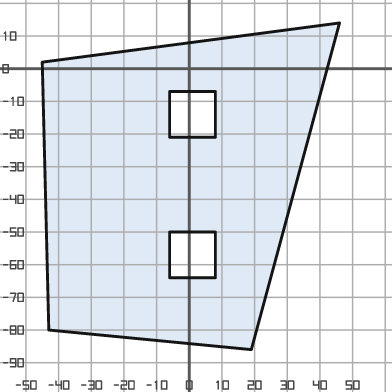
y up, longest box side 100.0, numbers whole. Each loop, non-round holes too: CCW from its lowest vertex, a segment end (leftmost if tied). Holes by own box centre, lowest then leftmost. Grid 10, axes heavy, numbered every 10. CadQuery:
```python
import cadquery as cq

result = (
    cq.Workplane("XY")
    .moveTo(19.0, -86.0)
    .lineTo(46.0, 14.0)
    .lineTo(-45.0, 2.0)
    .lineTo(-43.0, -80.0)
    .close()
    .moveTo(-6.0, -64.0)
    .lineTo(8.0, -64.0)
    .lineTo(8.0, -50.0)
    .lineTo(-6.0, -50.0)
    .close()
    .moveTo(-6.0, -21.0)
    .lineTo(8.0, -21.0)
    .lineTo(8.0, -7.0)
    .lineTo(-6.0, -7.0)
    .close()
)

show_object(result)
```